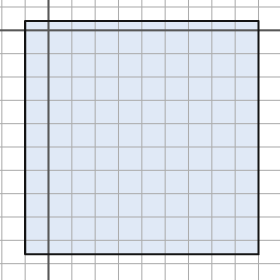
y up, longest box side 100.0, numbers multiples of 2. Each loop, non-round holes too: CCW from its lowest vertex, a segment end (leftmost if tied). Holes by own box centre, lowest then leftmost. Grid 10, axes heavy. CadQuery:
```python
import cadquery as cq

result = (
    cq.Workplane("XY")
    .moveTo(-10.0, -96.0)
    .lineTo(90.0, -96.0)
    .lineTo(90.0, 4.0)
    .lineTo(-10.0, 4.0)
    .close()
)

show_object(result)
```